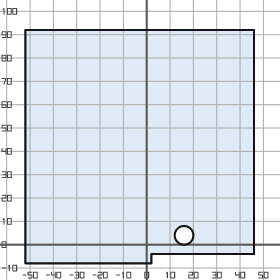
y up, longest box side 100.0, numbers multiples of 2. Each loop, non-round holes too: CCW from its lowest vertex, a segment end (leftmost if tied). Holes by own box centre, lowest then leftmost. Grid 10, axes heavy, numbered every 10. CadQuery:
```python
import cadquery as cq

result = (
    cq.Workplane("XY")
    .moveTo(-52.0, -8.0)
    .lineTo(2.0, -8.0)
    .lineTo(2.0, -4.0)
    .lineTo(46.0, -4.0)
    .lineTo(46.0, 92.0)
    .lineTo(-52.0, 92.0)
    .close()
    .moveTo(16.0, 4.0)
    .circle(4.0)
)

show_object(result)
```